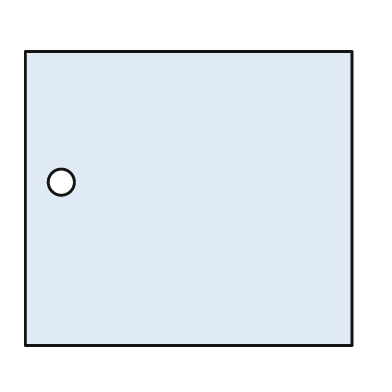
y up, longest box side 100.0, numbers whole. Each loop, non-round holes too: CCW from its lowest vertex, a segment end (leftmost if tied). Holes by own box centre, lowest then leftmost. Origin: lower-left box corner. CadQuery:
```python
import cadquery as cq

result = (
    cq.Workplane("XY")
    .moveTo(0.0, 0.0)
    .lineTo(100.0, 0.0)
    .lineTo(100.0, 90.0)
    .lineTo(0.0, 90.0)
    .close()
    .moveTo(11.0, 50.0)
    .circle(4.0)
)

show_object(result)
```